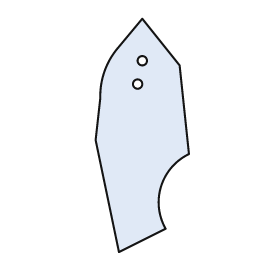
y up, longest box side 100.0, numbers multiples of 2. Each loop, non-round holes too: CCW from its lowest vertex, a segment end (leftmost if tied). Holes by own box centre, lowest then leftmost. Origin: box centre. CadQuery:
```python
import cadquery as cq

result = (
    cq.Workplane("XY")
    .moveTo(-10.0, -50.0)
    .lineTo(10.0, -40.0)
    .threePointArc((8.0, -22.0), (20.0, -8.0))
    .lineTo(16.0, 30.0)
    .lineTo(0.0, 50.0)
    .lineTo(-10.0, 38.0)
    .threePointArc((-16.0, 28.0), (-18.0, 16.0))
    .lineTo(-20.0, -2.0)
    .close()
    .moveTo(-2.0, 22.0)
    .circle(2.0)
    .moveTo(0.0, 32.0)
    .circle(2.0)
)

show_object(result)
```